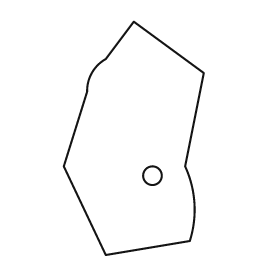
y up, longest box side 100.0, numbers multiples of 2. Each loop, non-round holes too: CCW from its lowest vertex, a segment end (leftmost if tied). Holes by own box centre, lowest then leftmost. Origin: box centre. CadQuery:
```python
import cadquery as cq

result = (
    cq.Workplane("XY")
    .moveTo(-12.0, -50.0)
    .lineTo(24.0, -44.0)
    .threePointArc((26.0, -28.0), (22.0, -12.0))
    .lineTo(30.0, 28.0)
    .lineTo(0.0, 50.0)
    .lineTo(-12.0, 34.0)
    .threePointArc((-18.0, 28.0), (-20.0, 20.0))
    .lineTo(-30.0, -12.0)
    .close()
    .moveTo(8.0, -16.0)
    .circle(4.0)
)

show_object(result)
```